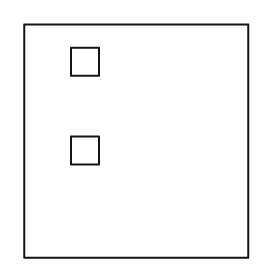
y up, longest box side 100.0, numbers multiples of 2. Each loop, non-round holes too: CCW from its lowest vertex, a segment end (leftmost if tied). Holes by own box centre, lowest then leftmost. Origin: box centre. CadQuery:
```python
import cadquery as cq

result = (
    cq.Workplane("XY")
    .moveTo(-48.0, -50.0)
    .lineTo(48.0, -50.0)
    .lineTo(48.0, 50.0)
    .lineTo(-48.0, 50.0)
    .close()
    .moveTo(-28.0, -10.0)
    .lineTo(-16.0, -10.0)
    .lineTo(-16.0, 2.0)
    .lineTo(-28.0, 2.0)
    .close()
    .moveTo(-28.0, 28.0)
    .lineTo(-16.0, 28.0)
    .lineTo(-16.0, 40.0)
    .lineTo(-28.0, 40.0)
    .close()
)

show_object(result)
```